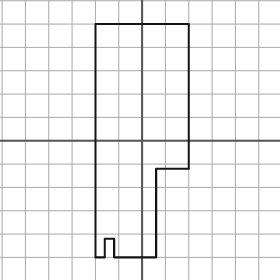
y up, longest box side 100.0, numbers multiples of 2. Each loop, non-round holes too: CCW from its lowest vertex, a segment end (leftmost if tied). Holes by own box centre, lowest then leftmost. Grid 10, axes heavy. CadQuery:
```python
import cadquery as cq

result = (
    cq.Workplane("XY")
    .moveTo(-20.0, -50.0)
    .lineTo(-16.0, -50.0)
    .lineTo(-16.0, -42.0)
    .lineTo(-12.0, -42.0)
    .lineTo(-12.0, -50.0)
    .lineTo(6.0, -50.0)
    .lineTo(6.0, -12.0)
    .lineTo(20.0, -12.0)
    .lineTo(20.0, 50.0)
    .lineTo(-20.0, 50.0)
    .close()
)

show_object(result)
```